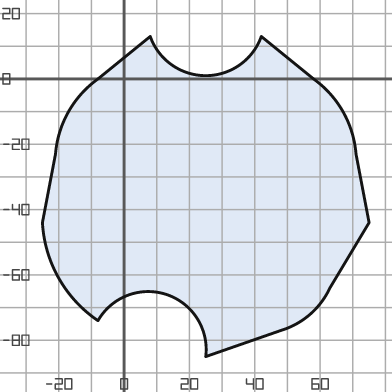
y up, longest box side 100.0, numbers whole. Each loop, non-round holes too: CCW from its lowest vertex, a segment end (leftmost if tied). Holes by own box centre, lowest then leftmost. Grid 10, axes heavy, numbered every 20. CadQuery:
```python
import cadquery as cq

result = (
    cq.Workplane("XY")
    .moveTo(25.0, -85.0)
    .lineTo(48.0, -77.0)
    .threePointArc((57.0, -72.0), (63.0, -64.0))
    .lineTo(75.0, -44.0)
    .lineTo(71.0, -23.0)
    .threePointArc((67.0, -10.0), (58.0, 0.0))
    .lineTo(42.0, 13.0)
    .threePointArc((25.0, 1.0), (8.0, 13.0))
    .lineTo(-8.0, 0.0)
    .threePointArc((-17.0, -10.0), (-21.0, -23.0))
    .lineTo(-25.0, -44.0)
    .threePointArc((-20.0, -61.0), (-8.0, -74.0))
    .threePointArc((13.0, -66.0), (25.0, -85.0))
    .close()
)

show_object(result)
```